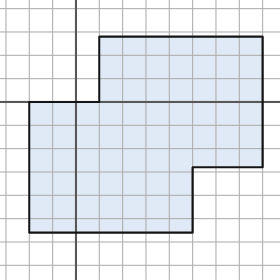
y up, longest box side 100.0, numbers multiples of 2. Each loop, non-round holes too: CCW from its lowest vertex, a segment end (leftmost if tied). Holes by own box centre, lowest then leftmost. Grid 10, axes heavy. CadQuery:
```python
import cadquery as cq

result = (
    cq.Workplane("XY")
    .moveTo(-20.0, -56.0)
    .lineTo(50.0, -56.0)
    .lineTo(50.0, -28.0)
    .lineTo(80.0, -28.0)
    .lineTo(80.0, 28.0)
    .lineTo(10.0, 28.0)
    .lineTo(10.0, 0.0)
    .lineTo(-20.0, 0.0)
    .close()
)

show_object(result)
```